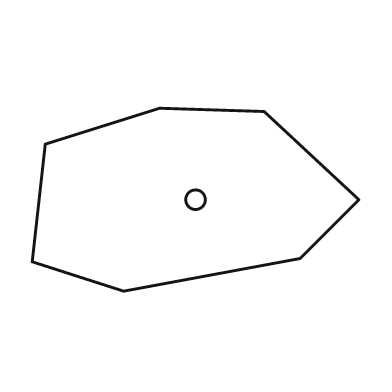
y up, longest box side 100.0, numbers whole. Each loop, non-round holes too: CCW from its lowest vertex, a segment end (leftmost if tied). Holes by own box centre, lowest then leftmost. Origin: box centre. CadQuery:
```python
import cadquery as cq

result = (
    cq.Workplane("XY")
    .moveTo(-22.0, -28.0)
    .lineTo(32.0, -18.0)
    .lineTo(50.0, 0.0)
    .lineTo(21.0, 27.0)
    .lineTo(-11.0, 28.0)
    .lineTo(-46.0, 17.0)
    .lineTo(-50.0, -19.0)
    .close()
    .moveTo(0.0, 0.0)
    .circle(3.0)
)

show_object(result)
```